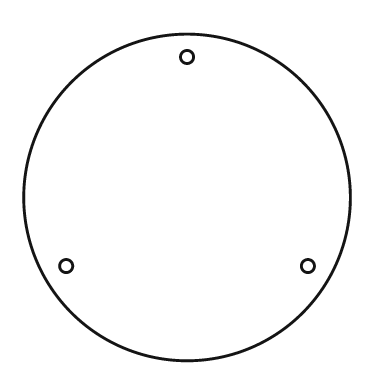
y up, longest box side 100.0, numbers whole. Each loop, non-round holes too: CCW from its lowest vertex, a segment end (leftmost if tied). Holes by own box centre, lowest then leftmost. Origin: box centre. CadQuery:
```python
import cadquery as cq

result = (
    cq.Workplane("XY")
    .moveTo(0.0, 0.0)
    .circle(50.0)
    .moveTo(-37.0, -21.0)
    .circle(2.0)
    .moveTo(37.0, -21.0)
    .circle(2.0)
    .moveTo(0.0, 43.0)
    .circle(2.0)
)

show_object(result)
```